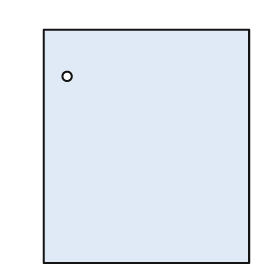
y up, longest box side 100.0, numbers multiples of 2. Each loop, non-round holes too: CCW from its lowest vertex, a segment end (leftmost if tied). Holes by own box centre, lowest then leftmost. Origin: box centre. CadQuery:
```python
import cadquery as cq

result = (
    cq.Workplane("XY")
    .moveTo(-44.0, -50.0)
    .lineTo(44.0, -50.0)
    .lineTo(44.0, 50.0)
    .lineTo(-44.0, 50.0)
    .close()
    .moveTo(-34.0, 30.0)
    .circle(2.0)
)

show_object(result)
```